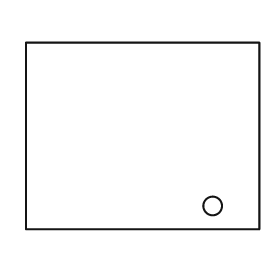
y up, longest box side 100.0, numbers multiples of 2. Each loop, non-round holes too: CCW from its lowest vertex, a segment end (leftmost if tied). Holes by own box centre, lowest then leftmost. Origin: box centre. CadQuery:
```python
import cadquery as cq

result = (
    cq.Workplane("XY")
    .moveTo(-50.0, -40.0)
    .lineTo(50.0, -40.0)
    .lineTo(50.0, 40.0)
    .lineTo(-50.0, 40.0)
    .close()
    .moveTo(30.0, -30.0)
    .circle(4.0)
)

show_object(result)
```